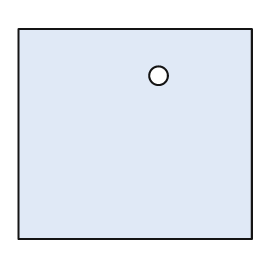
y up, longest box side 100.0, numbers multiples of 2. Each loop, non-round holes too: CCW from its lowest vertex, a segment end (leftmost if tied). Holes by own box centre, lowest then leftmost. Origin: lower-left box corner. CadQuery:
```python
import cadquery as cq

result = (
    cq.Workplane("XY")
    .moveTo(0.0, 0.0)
    .lineTo(100.0, 0.0)
    .lineTo(100.0, 90.0)
    .lineTo(0.0, 90.0)
    .close()
    .moveTo(60.0, 70.0)
    .circle(4.0)
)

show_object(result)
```